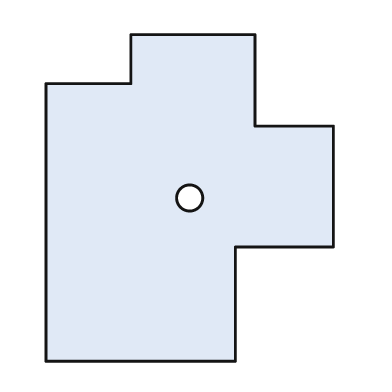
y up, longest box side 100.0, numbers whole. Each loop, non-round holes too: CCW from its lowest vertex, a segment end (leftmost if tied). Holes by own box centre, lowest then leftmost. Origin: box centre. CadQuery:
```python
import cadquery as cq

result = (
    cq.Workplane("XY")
    .moveTo(-44.0, -50.0)
    .lineTo(14.0, -50.0)
    .lineTo(14.0, -15.0)
    .lineTo(44.0, -15.0)
    .lineTo(44.0, 22.0)
    .lineTo(20.0, 22.0)
    .lineTo(20.0, 50.0)
    .lineTo(-18.0, 50.0)
    .lineTo(-18.0, 35.0)
    .lineTo(-44.0, 35.0)
    .close()
    .moveTo(0.0, 0.0)
    .circle(4.0)
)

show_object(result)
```